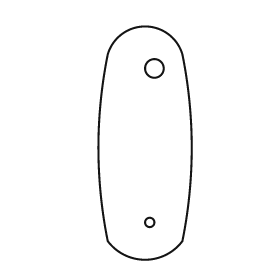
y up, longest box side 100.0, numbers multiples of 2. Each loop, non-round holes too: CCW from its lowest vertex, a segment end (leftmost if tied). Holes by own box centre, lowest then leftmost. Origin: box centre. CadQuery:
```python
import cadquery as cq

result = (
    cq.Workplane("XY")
    .moveTo(-16.0, -42.0)
    .threePointArc((0.0, -50.0), (16.0, -42.0))
    .threePointArc((20.0, -2.0), (16.0, 38.0))
    .threePointArc((0.0, 50.0), (-16.0, 38.0))
    .threePointArc((-20.0, -2.0), (-16.0, -42.0))
    .close()
    .moveTo(2.0, -34.0)
    .circle(2.0)
    .moveTo(4.0, 32.0)
    .circle(4.0)
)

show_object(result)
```